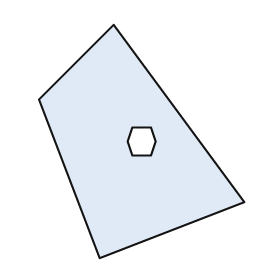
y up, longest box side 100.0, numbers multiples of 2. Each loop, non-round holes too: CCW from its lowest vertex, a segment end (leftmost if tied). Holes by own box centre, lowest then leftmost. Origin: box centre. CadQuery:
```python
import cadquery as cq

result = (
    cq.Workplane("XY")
    .moveTo(-18.0, -50.0)
    .lineTo(44.0, -26.0)
    .lineTo(-12.0, 50.0)
    .lineTo(-44.0, 18.0)
    .close()
    .moveTo(-4.0, -6.0)
    .lineTo(4.0, -6.0)
    .lineTo(6.0, 0.0)
    .lineTo(4.0, 6.0)
    .lineTo(-4.0, 6.0)
    .lineTo(-6.0, 0.0)
    .close()
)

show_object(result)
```